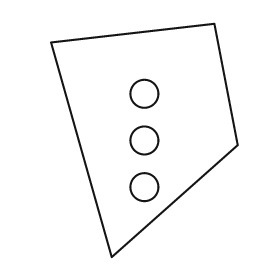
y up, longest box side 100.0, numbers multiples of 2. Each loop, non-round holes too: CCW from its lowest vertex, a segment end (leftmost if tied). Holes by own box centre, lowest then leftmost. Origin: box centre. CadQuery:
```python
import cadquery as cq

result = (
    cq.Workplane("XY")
    .moveTo(-14.0, -50.0)
    .lineTo(40.0, -2.0)
    .lineTo(30.0, 50.0)
    .lineTo(-40.0, 42.0)
    .close()
    .moveTo(0.0, -20.0)
    .circle(6.0)
    .moveTo(0.0, 0.0)
    .circle(6.0)
    .moveTo(0.0, 20.0)
    .circle(6.0)
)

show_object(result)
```